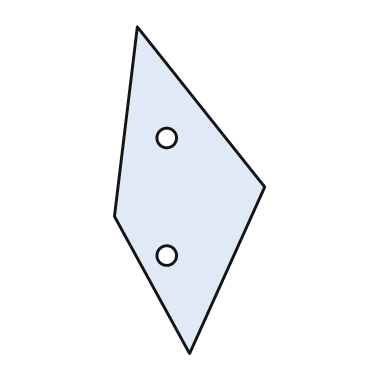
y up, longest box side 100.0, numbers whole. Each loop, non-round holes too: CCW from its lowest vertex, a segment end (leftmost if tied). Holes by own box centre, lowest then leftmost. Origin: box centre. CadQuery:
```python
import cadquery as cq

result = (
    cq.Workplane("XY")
    .moveTo(0.0, -50.0)
    .lineTo(23.0, 1.0)
    .lineTo(-16.0, 50.0)
    .lineTo(-23.0, -8.0)
    .close()
    .moveTo(-7.0, -20.0)
    .circle(3.0)
    .moveTo(-7.0, 16.0)
    .circle(3.0)
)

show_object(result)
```